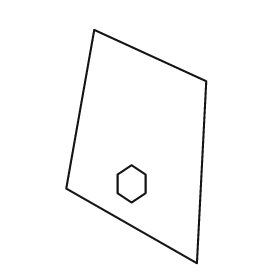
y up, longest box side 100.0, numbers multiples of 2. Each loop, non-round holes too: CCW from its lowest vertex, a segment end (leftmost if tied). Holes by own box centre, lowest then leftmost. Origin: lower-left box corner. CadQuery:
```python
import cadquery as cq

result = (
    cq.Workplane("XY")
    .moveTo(56.0, 0.0)
    .lineTo(60.0, 78.0)
    .lineTo(12.0, 100.0)
    .lineTo(0.0, 32.0)
    .close()
    .moveTo(28.0, 26.0)
    .lineTo(34.0, 30.0)
    .lineTo(34.0, 38.0)
    .lineTo(28.0, 42.0)
    .lineTo(22.0, 38.0)
    .lineTo(22.0, 30.0)
    .close()
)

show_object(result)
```